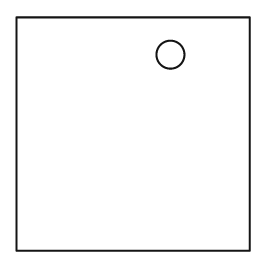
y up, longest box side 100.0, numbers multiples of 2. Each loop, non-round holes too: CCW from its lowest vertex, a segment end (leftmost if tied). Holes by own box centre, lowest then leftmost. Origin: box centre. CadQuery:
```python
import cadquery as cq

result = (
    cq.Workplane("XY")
    .moveTo(-50.0, -50.0)
    .lineTo(50.0, -50.0)
    .lineTo(50.0, 50.0)
    .lineTo(-50.0, 50.0)
    .close()
    .moveTo(16.0, 34.0)
    .circle(6.0)
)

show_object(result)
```